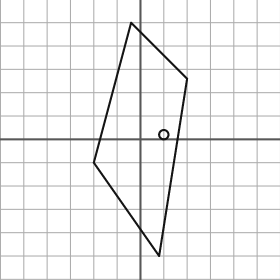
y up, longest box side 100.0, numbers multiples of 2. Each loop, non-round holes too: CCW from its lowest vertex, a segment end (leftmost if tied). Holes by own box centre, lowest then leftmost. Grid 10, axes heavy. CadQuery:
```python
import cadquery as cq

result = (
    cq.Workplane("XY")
    .moveTo(8.0, -50.0)
    .lineTo(20.0, 26.0)
    .lineTo(-4.0, 50.0)
    .lineTo(-20.0, -10.0)
    .close()
    .moveTo(10.0, 2.0)
    .circle(2.0)
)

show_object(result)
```